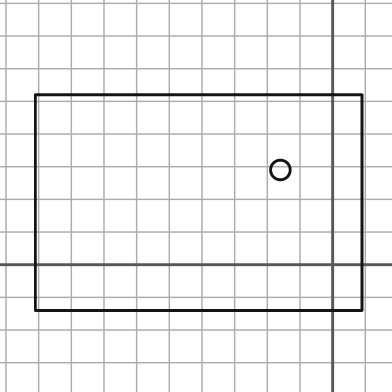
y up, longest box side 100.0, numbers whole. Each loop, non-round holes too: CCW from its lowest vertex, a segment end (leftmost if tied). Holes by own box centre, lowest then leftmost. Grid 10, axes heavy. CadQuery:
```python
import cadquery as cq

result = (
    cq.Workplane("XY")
    .moveTo(-91.0, -14.0)
    .lineTo(9.0, -14.0)
    .lineTo(9.0, 52.0)
    .lineTo(-91.0, 52.0)
    .close()
    .moveTo(-16.0, 29.0)
    .circle(3.0)
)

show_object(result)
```